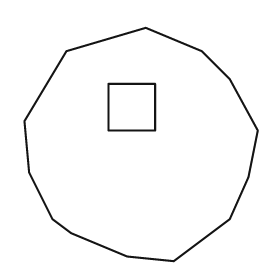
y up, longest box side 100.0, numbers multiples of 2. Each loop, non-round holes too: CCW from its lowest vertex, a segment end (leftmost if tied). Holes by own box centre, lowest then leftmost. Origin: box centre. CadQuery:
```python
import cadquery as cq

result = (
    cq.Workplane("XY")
    .moveTo(14.0, -50.0)
    .lineTo(38.0, -32.0)
    .lineTo(46.0, -14.0)
    .lineTo(50.0, 6.0)
    .lineTo(38.0, 28.0)
    .lineTo(26.0, 40.0)
    .lineTo(2.0, 50.0)
    .lineTo(-32.0, 40.0)
    .lineTo(-50.0, 10.0)
    .lineTo(-48.0, -12.0)
    .lineTo(-38.0, -32.0)
    .lineTo(-30.0, -38.0)
    .lineTo(-6.0, -48.0)
    .close()
    .moveTo(-14.0, 6.0)
    .lineTo(6.0, 6.0)
    .lineTo(6.0, 26.0)
    .lineTo(-14.0, 26.0)
    .close()
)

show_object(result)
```